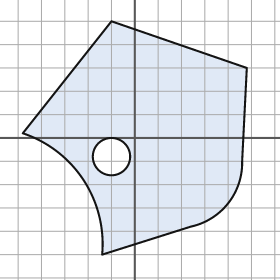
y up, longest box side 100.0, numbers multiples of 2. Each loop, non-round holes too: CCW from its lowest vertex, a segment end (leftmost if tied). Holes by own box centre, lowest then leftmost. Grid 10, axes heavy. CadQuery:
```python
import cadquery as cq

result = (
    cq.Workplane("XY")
    .moveTo(-14.0, -50.0)
    .lineTo(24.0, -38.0)
    .threePointArc((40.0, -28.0), (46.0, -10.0))
    .lineTo(48.0, 30.0)
    .lineTo(-10.0, 50.0)
    .lineTo(-48.0, 2.0)
    .threePointArc((-22.0, -18.0), (-14.0, -50.0))
    .close()
    .moveTo(-10.0, -8.0)
    .circle(8.0)
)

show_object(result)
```